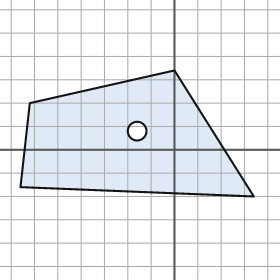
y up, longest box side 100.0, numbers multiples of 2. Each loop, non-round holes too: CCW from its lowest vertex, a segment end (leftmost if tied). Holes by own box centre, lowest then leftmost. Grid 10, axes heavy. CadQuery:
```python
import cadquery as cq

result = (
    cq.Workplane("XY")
    .moveTo(34.0, -20.0)
    .lineTo(0.0, 34.0)
    .lineTo(-62.0, 20.0)
    .lineTo(-66.0, -16.0)
    .close()
    .moveTo(-16.0, 8.0)
    .circle(4.0)
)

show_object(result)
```